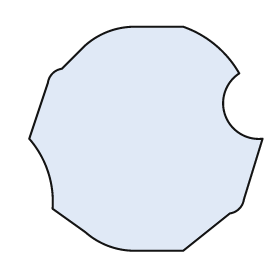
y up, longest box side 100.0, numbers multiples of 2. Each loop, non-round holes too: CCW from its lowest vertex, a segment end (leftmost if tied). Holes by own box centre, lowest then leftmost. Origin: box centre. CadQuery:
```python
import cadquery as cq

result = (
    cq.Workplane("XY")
    .moveTo(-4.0, -48.0)
    .lineTo(16.0, -48.0)
    .lineTo(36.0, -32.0)
    .threePointArc((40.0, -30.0), (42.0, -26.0))
    .lineTo(50.0, 0.0)
    .threePointArc((34.0, 10.0), (40.0, 28.0))
    .threePointArc((30.0, 40.0), (16.0, 48.0))
    .lineTo(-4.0, 48.0)
    .threePointArc((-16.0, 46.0), (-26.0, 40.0))
    .lineTo(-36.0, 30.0)
    .threePointArc((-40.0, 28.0), (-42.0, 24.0))
    .lineTo(-50.0, 0.0)
    .threePointArc((-42.0, -14.0), (-40.0, -30.0))
    .lineTo(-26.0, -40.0)
    .threePointArc((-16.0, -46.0), (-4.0, -48.0))
    .close()
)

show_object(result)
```